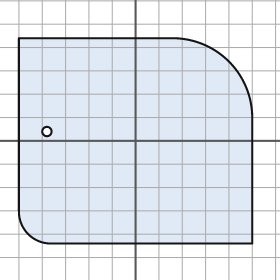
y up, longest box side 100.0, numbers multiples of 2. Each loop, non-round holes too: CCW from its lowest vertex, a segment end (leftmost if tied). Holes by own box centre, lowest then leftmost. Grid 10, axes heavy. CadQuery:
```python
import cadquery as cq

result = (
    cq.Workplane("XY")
    .moveTo(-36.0, -44.0)
    .lineTo(50.0, -44.0)
    .lineTo(50.0, 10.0)
    .threePointArc((40.0, 34.0), (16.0, 44.0))
    .lineTo(-50.0, 44.0)
    .lineTo(-50.0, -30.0)
    .threePointArc((-46.0, -40.0), (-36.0, -44.0))
    .close()
    .moveTo(-38.0, 4.0)
    .circle(2.0)
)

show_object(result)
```